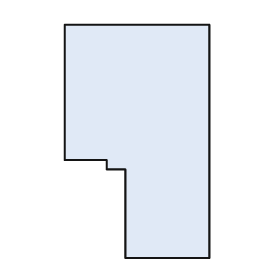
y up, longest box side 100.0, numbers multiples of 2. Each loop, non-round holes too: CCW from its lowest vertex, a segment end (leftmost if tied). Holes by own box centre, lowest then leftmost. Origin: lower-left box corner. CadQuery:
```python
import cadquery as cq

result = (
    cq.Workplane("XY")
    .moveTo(26.0, 0.0)
    .lineTo(62.0, 0.0)
    .lineTo(62.0, 100.0)
    .lineTo(0.0, 100.0)
    .lineTo(0.0, 42.0)
    .lineTo(18.0, 42.0)
    .lineTo(18.0, 38.0)
    .lineTo(26.0, 38.0)
    .close()
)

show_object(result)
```